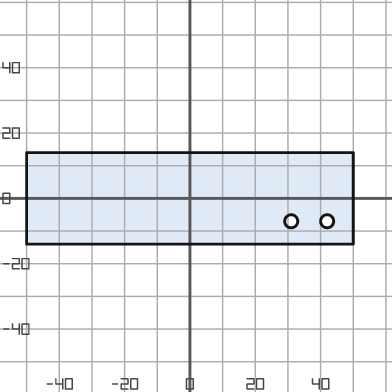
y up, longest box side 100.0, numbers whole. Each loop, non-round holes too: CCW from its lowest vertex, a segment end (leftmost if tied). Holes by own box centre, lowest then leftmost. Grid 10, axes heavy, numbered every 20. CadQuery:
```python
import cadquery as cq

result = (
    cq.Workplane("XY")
    .moveTo(-50.0, -14.0)
    .lineTo(50.0, -14.0)
    .lineTo(50.0, 14.0)
    .lineTo(-50.0, 14.0)
    .close()
    .moveTo(31.0, -7.0)
    .circle(2.0)
    .moveTo(42.0, -7.0)
    .circle(2.0)
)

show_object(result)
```